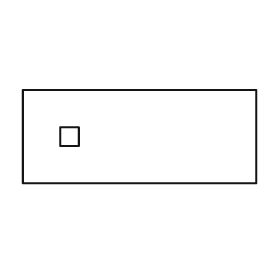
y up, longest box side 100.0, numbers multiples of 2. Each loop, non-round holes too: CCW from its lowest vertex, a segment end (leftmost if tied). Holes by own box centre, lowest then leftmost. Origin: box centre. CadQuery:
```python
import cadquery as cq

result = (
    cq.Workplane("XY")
    .moveTo(-50.0, -20.0)
    .lineTo(50.0, -20.0)
    .lineTo(50.0, 20.0)
    .lineTo(-50.0, 20.0)
    .close()
    .moveTo(-34.0, -4.0)
    .lineTo(-26.0, -4.0)
    .lineTo(-26.0, 4.0)
    .lineTo(-34.0, 4.0)
    .close()
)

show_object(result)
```